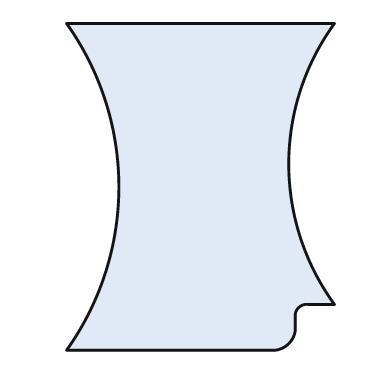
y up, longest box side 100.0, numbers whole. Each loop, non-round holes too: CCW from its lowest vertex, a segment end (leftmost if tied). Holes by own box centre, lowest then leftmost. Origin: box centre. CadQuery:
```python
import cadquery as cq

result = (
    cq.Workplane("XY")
    .moveTo(-41.0, -50.0)
    .lineTo(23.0, -50.0)
    .threePointArc((27.0, -48.0), (29.0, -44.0))
    .lineTo(29.0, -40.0)
    .threePointArc((30.0, -37.0), (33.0, -36.0))
    .lineTo(41.0, -36.0)
    .threePointArc((27.0, 7.0), (41.0, 50.0))
    .lineTo(-41.0, 50.0)
    .threePointArc((-25.0, 0.0), (-41.0, -50.0))
    .close()
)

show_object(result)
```